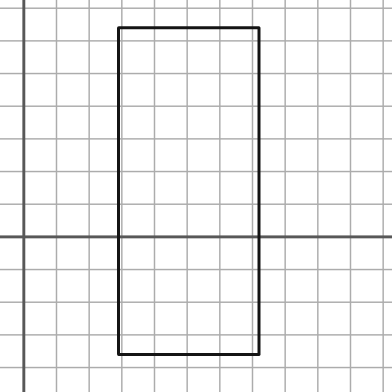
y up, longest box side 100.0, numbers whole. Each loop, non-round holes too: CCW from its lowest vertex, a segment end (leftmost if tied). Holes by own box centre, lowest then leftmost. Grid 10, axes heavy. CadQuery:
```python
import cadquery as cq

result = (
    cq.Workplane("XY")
    .moveTo(29.0, -36.0)
    .lineTo(72.0, -36.0)
    .lineTo(72.0, 64.0)
    .lineTo(29.0, 64.0)
    .close()
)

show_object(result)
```